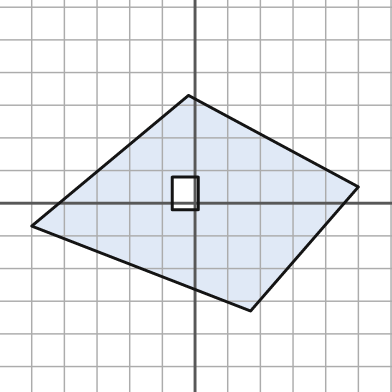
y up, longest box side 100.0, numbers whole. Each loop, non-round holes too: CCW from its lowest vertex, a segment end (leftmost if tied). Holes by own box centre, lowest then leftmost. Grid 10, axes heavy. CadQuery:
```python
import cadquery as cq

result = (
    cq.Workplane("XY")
    .moveTo(17.0, -33.0)
    .lineTo(50.0, 5.0)
    .lineTo(-2.0, 33.0)
    .lineTo(-50.0, -7.0)
    .close()
    .moveTo(-7.0, -2.0)
    .lineTo(1.0, -2.0)
    .lineTo(1.0, 8.0)
    .lineTo(-7.0, 8.0)
    .close()
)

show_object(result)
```